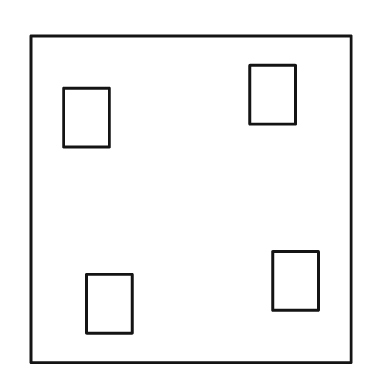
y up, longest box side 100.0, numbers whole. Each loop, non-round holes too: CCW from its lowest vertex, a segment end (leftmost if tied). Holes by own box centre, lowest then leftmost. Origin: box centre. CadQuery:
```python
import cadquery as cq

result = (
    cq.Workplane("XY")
    .moveTo(-49.0, -50.0)
    .lineTo(49.0, -50.0)
    .lineTo(49.0, 50.0)
    .lineTo(-49.0, 50.0)
    .close()
    .moveTo(-32.0, -41.0)
    .lineTo(-18.0, -41.0)
    .lineTo(-18.0, -23.0)
    .lineTo(-32.0, -23.0)
    .close()
    .moveTo(25.0, -34.0)
    .lineTo(39.0, -34.0)
    .lineTo(39.0, -16.0)
    .lineTo(25.0, -16.0)
    .close()
    .moveTo(-39.0, 16.0)
    .lineTo(-25.0, 16.0)
    .lineTo(-25.0, 34.0)
    .lineTo(-39.0, 34.0)
    .close()
    .moveTo(18.0, 23.0)
    .lineTo(32.0, 23.0)
    .lineTo(32.0, 41.0)
    .lineTo(18.0, 41.0)
    .close()
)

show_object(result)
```